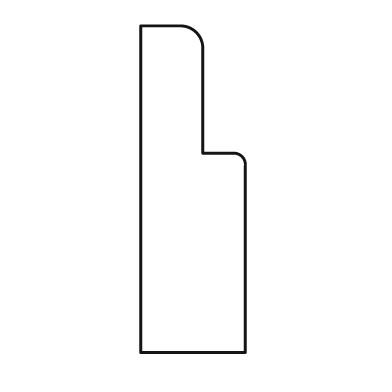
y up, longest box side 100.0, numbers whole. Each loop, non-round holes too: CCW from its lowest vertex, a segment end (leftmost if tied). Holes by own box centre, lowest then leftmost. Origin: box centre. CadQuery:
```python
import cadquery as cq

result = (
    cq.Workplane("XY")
    .moveTo(-16.0, -50.0)
    .lineTo(16.0, -50.0)
    .lineTo(16.0, 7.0)
    .threePointArc((15.0, 10.0), (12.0, 11.0))
    .lineTo(3.0, 11.0)
    .lineTo(3.0, 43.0)
    .threePointArc((1.0, 48.0), (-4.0, 50.0))
    .lineTo(-16.0, 50.0)
    .close()
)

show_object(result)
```